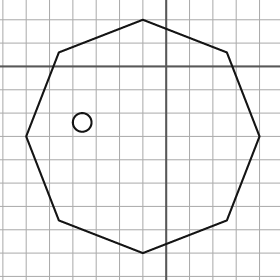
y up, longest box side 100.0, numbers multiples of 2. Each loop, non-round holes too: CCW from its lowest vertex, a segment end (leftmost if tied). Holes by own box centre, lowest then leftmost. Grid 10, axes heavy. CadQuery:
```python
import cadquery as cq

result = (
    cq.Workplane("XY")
    .moveTo(-10.0, -80.0)
    .lineTo(26.0, -66.0)
    .lineTo(40.0, -30.0)
    .lineTo(26.0, 6.0)
    .lineTo(-10.0, 20.0)
    .lineTo(-46.0, 6.0)
    .lineTo(-60.0, -30.0)
    .lineTo(-46.0, -66.0)
    .close()
    .moveTo(-36.0, -24.0)
    .circle(4.0)
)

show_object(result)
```